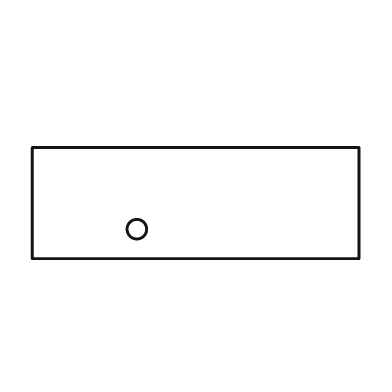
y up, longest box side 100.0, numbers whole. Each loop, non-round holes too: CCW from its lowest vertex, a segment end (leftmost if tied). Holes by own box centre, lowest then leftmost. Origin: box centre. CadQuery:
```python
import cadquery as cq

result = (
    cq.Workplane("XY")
    .moveTo(-50.0, -17.0)
    .lineTo(50.0, -17.0)
    .lineTo(50.0, 17.0)
    .lineTo(-50.0, 17.0)
    .close()
    .moveTo(-18.0, -8.0)
    .circle(3.0)
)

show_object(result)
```